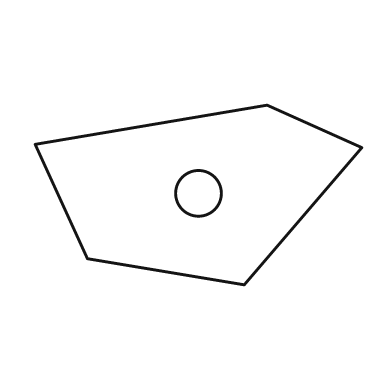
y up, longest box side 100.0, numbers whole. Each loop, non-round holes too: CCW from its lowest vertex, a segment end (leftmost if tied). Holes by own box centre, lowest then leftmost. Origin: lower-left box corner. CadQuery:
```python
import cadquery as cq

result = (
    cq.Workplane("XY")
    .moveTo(64.0, 0.0)
    .lineTo(100.0, 42.0)
    .lineTo(71.0, 55.0)
    .lineTo(0.0, 43.0)
    .lineTo(16.0, 8.0)
    .close()
    .moveTo(50.0, 28.0)
    .circle(7.0)
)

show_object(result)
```